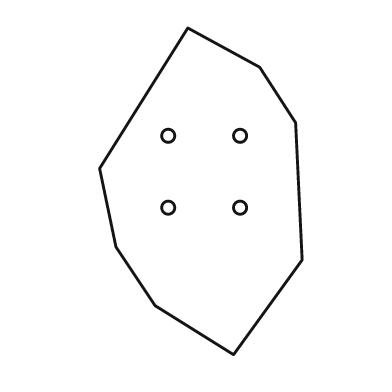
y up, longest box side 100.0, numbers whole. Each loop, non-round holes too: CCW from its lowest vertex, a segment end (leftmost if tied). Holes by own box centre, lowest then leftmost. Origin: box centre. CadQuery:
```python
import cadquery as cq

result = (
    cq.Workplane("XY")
    .moveTo(10.0, -50.0)
    .lineTo(31.0, -21.0)
    .lineTo(29.0, 21.0)
    .lineTo(18.0, 38.0)
    .lineTo(-4.0, 50.0)
    .lineTo(-31.0, 7.0)
    .lineTo(-26.0, -17.0)
    .lineTo(-14.0, -35.0)
    .close()
    .moveTo(-10.0, -5.0)
    .circle(2.0)
    .moveTo(12.0, -5.0)
    .circle(2.0)
    .moveTo(-10.0, 17.0)
    .circle(2.0)
    .moveTo(12.0, 17.0)
    .circle(2.0)
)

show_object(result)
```